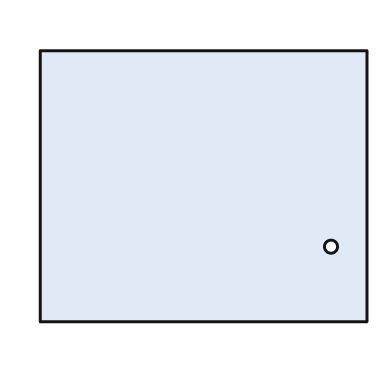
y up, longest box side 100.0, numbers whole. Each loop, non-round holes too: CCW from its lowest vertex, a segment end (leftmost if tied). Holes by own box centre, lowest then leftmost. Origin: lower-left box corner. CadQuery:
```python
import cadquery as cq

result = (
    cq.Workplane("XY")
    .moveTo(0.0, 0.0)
    .lineTo(100.0, 0.0)
    .lineTo(100.0, 83.0)
    .lineTo(0.0, 83.0)
    .close()
    .moveTo(89.0, 23.0)
    .circle(2.0)
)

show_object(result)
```